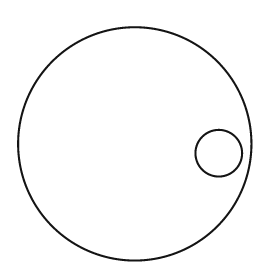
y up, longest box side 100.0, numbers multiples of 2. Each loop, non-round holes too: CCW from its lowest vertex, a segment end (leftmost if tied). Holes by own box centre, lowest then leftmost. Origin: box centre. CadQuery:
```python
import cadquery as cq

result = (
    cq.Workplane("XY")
    .moveTo(0.0, 0.0)
    .circle(50.0)
    .moveTo(36.0, -4.0)
    .circle(10.0)
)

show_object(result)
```